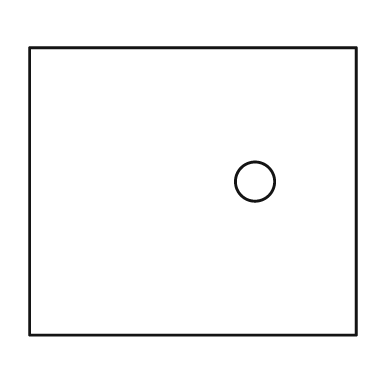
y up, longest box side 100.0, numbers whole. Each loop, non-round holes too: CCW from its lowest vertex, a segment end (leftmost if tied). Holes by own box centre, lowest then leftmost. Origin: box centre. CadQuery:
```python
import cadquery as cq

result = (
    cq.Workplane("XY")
    .moveTo(-50.0, -44.0)
    .lineTo(50.0, -44.0)
    .lineTo(50.0, 44.0)
    .lineTo(-50.0, 44.0)
    .close()
    .moveTo(19.0, 3.0)
    .circle(6.0)
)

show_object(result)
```